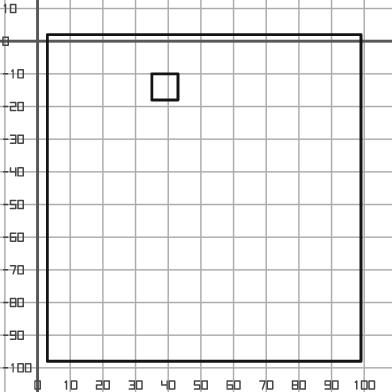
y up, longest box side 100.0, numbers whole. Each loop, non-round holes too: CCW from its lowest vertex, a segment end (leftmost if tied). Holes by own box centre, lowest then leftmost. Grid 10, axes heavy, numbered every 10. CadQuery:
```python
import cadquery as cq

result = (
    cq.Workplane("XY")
    .moveTo(3.0, -98.0)
    .lineTo(99.0, -98.0)
    .lineTo(99.0, 2.0)
    .lineTo(3.0, 2.0)
    .close()
    .moveTo(35.0, -18.0)
    .lineTo(43.0, -18.0)
    .lineTo(43.0, -10.0)
    .lineTo(35.0, -10.0)
    .close()
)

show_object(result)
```